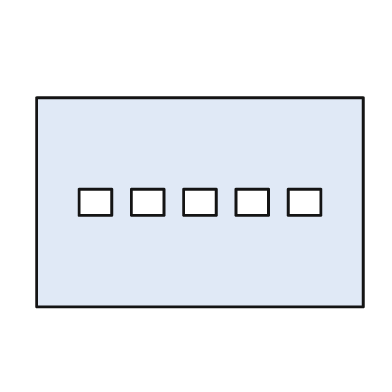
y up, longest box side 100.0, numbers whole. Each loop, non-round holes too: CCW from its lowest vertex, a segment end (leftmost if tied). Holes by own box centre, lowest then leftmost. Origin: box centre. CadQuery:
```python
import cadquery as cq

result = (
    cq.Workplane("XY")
    .moveTo(-50.0, -32.0)
    .lineTo(50.0, -32.0)
    .lineTo(50.0, 32.0)
    .lineTo(-50.0, 32.0)
    .close()
    .moveTo(-37.0, -4.0)
    .lineTo(-27.0, -4.0)
    .lineTo(-27.0, 4.0)
    .lineTo(-37.0, 4.0)
    .close()
    .moveTo(-21.0, -4.0)
    .lineTo(-11.0, -4.0)
    .lineTo(-11.0, 4.0)
    .lineTo(-21.0, 4.0)
    .close()
    .moveTo(-5.0, -4.0)
    .lineTo(5.0, -4.0)
    .lineTo(5.0, 4.0)
    .lineTo(-5.0, 4.0)
    .close()
    .moveTo(11.0, -4.0)
    .lineTo(21.0, -4.0)
    .lineTo(21.0, 4.0)
    .lineTo(11.0, 4.0)
    .close()
    .moveTo(27.0, -4.0)
    .lineTo(37.0, -4.0)
    .lineTo(37.0, 4.0)
    .lineTo(27.0, 4.0)
    .close()
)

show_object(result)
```